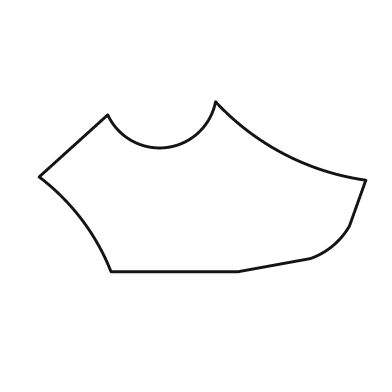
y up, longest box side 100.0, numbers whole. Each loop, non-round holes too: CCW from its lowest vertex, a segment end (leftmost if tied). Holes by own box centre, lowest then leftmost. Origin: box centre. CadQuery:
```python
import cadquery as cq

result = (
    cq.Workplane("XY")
    .moveTo(-28.0, -26.0)
    .lineTo(11.0, -26.0)
    .lineTo(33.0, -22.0)
    .threePointArc((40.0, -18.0), (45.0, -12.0))
    .lineTo(50.0, 2.0)
    .threePointArc((25.0, 10.0), (4.0, 26.0))
    .threePointArc((-11.0, 12.0), (-29.0, 22.0))
    .lineTo(-50.0, 3.0)
    .threePointArc((-37.0, -10.0), (-28.0, -26.0))
    .close()
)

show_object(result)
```